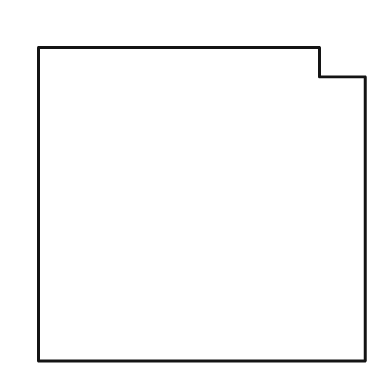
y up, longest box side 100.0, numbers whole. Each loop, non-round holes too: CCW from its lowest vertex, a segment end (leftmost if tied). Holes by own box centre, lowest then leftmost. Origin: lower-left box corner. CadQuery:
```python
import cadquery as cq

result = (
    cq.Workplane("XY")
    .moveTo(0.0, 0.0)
    .lineTo(100.0, 0.0)
    .lineTo(100.0, 87.0)
    .lineTo(86.0, 87.0)
    .lineTo(86.0, 96.0)
    .lineTo(0.0, 96.0)
    .close()
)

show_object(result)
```